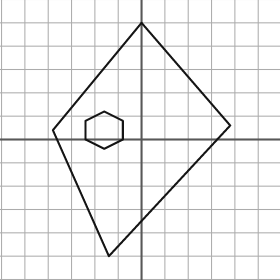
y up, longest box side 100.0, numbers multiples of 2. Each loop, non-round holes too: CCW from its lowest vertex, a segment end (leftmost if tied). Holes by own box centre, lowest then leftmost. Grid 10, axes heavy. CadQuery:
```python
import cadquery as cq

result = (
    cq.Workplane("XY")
    .moveTo(-14.0, -50.0)
    .lineTo(38.0, 6.0)
    .lineTo(0.0, 50.0)
    .lineTo(-38.0, 4.0)
    .close()
    .moveTo(-16.0, -4.0)
    .lineTo(-8.0, 0.0)
    .lineTo(-8.0, 8.0)
    .lineTo(-16.0, 12.0)
    .lineTo(-24.0, 8.0)
    .lineTo(-24.0, 0.0)
    .close()
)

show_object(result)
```